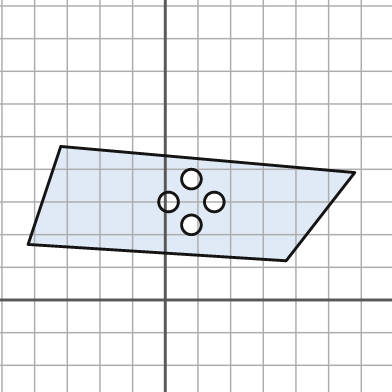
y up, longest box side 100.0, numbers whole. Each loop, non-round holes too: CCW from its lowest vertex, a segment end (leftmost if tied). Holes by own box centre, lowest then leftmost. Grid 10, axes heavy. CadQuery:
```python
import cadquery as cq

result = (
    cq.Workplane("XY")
    .moveTo(37.0, 12.0)
    .lineTo(58.0, 39.0)
    .lineTo(-32.0, 47.0)
    .lineTo(-42.0, 17.0)
    .close()
    .moveTo(8.0, 23.0)
    .circle(3.0)
    .moveTo(1.0, 30.0)
    .circle(3.0)
    .moveTo(15.0, 30.0)
    .circle(3.0)
    .moveTo(8.0, 37.0)
    .circle(3.0)
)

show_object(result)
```